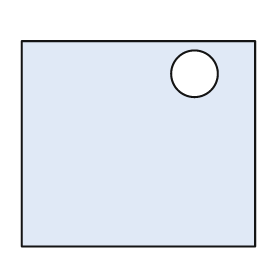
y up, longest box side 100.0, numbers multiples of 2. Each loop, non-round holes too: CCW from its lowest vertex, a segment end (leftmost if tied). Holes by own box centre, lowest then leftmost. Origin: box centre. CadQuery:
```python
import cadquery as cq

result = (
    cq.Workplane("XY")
    .moveTo(-50.0, -44.0)
    .lineTo(50.0, -44.0)
    .lineTo(50.0, 44.0)
    .lineTo(-50.0, 44.0)
    .close()
    .moveTo(24.0, 30.0)
    .circle(10.0)
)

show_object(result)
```